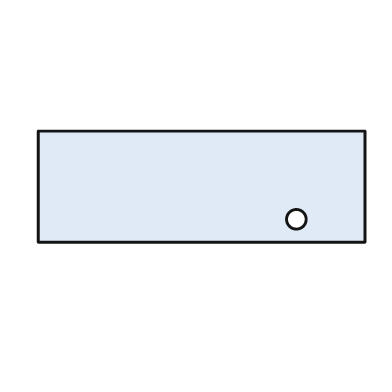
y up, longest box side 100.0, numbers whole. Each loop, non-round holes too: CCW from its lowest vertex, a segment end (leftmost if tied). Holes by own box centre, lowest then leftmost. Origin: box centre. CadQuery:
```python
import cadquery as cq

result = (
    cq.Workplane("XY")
    .moveTo(-50.0, -17.0)
    .lineTo(50.0, -17.0)
    .lineTo(50.0, 17.0)
    .lineTo(-50.0, 17.0)
    .close()
    .moveTo(29.0, -10.0)
    .circle(3.0)
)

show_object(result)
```